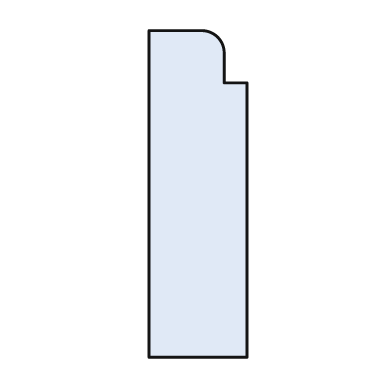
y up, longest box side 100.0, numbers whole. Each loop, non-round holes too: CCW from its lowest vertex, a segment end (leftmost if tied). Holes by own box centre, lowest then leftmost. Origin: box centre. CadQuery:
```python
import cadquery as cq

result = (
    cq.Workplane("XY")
    .moveTo(-15.0, -50.0)
    .lineTo(15.0, -50.0)
    .lineTo(15.0, 34.0)
    .lineTo(8.0, 34.0)
    .lineTo(8.0, 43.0)
    .threePointArc((6.0, 48.0), (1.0, 50.0))
    .lineTo(-15.0, 50.0)
    .close()
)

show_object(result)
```